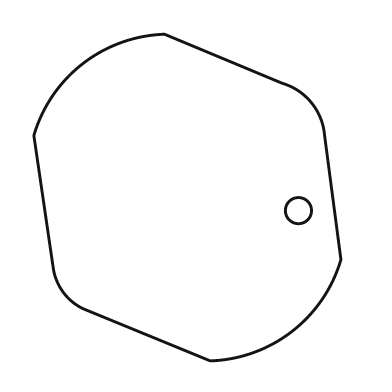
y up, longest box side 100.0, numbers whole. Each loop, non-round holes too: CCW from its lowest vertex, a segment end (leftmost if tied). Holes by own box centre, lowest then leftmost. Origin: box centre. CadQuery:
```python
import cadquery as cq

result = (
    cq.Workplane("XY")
    .moveTo(7.0, -50.0)
    .threePointArc((32.0, -41.0), (47.0, -19.0))
    .lineTo(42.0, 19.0)
    .threePointArc((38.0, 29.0), (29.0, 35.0))
    .lineTo(-7.0, 50.0)
    .threePointArc((-32.0, 41.0), (-47.0, 19.0))
    .lineTo(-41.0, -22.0)
    .threePointArc((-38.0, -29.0), (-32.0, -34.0))
    .close()
    .moveTo(34.0, -4.0)
    .circle(4.0)
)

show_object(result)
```